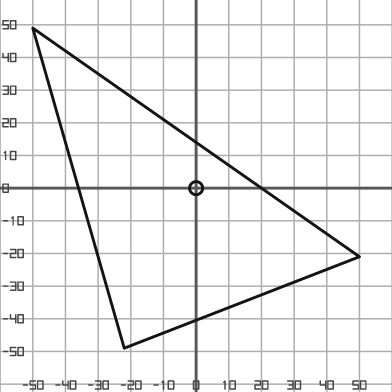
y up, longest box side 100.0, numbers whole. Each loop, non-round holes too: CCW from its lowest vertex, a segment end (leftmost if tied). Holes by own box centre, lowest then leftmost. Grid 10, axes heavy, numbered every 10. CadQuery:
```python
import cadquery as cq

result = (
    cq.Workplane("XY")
    .moveTo(-22.0, -49.0)
    .lineTo(50.0, -21.0)
    .lineTo(-50.0, 49.0)
    .close()
    .moveTo(0.0, 0.0)
    .circle(2.0)
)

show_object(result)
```